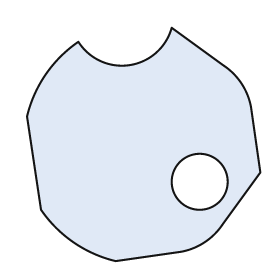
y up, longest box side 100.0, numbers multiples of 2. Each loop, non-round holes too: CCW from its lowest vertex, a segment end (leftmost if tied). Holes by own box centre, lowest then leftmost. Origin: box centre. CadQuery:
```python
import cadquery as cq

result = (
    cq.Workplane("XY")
    .moveTo(-12.0, -50.0)
    .lineTo(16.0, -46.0)
    .threePointArc((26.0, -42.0), (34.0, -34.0))
    .lineTo(50.0, -12.0)
    .lineTo(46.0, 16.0)
    .threePointArc((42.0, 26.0), (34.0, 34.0))
    .lineTo(12.0, 50.0)
    .threePointArc((-6.0, 34.0), (-28.0, 44.0))
    .threePointArc((-42.0, 30.0), (-50.0, 12.0))
    .lineTo(-44.0, -28.0)
    .threePointArc((-30.0, -42.0), (-12.0, -50.0))
    .close()
    .moveTo(24.0, -16.0)
    .circle(12.0)
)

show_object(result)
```